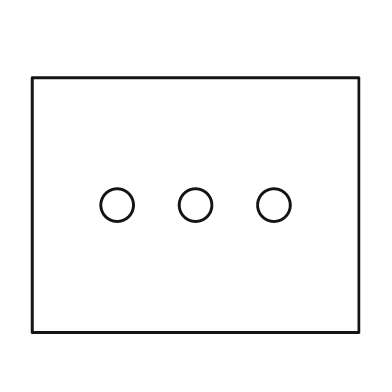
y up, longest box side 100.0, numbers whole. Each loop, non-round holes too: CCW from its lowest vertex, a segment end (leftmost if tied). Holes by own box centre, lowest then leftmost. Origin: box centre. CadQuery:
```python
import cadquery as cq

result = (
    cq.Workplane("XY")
    .moveTo(-50.0, -39.0)
    .lineTo(50.0, -39.0)
    .lineTo(50.0, 39.0)
    .lineTo(-50.0, 39.0)
    .close()
    .moveTo(-24.0, 0.0)
    .circle(5.0)
    .moveTo(0.0, 0.0)
    .circle(5.0)
    .moveTo(24.0, 0.0)
    .circle(5.0)
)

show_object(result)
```